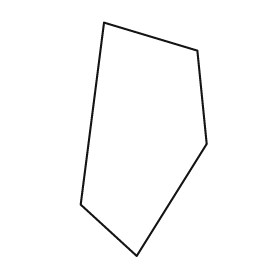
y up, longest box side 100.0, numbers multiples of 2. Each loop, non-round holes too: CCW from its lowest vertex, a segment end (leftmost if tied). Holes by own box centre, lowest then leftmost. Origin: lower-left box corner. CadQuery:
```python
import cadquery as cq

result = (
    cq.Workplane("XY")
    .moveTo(24.0, 0.0)
    .lineTo(54.0, 48.0)
    .lineTo(50.0, 88.0)
    .lineTo(10.0, 100.0)
    .lineTo(0.0, 22.0)
    .close()
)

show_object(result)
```